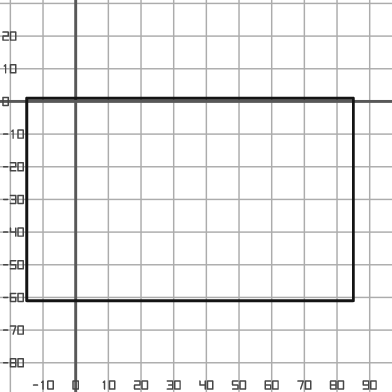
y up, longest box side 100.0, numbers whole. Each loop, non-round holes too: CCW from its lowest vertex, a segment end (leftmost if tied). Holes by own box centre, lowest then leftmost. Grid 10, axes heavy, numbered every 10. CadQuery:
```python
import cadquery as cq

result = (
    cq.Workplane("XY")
    .moveTo(-15.0, -61.0)
    .lineTo(85.0, -61.0)
    .lineTo(85.0, 1.0)
    .lineTo(-15.0, 1.0)
    .close()
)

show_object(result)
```